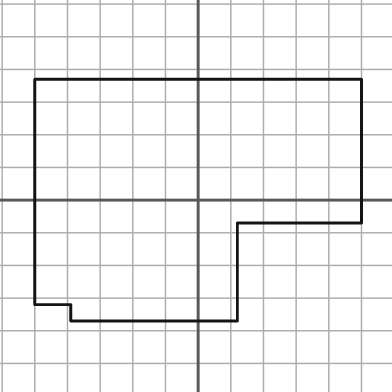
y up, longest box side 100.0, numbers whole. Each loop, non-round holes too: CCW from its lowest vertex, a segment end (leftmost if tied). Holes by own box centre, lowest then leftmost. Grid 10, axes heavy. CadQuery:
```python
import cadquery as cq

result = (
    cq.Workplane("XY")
    .moveTo(-39.0, -37.0)
    .lineTo(12.0, -37.0)
    .lineTo(12.0, -7.0)
    .lineTo(50.0, -7.0)
    .lineTo(50.0, 37.0)
    .lineTo(-50.0, 37.0)
    .lineTo(-50.0, -32.0)
    .lineTo(-39.0, -32.0)
    .close()
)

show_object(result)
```